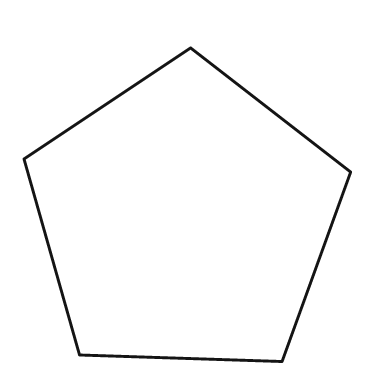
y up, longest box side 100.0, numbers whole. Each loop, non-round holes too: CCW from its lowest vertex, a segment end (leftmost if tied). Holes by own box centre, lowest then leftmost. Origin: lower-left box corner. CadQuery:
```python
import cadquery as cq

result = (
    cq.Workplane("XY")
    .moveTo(79.0, 0.0)
    .lineTo(100.0, 58.0)
    .lineTo(51.0, 96.0)
    .lineTo(0.0, 62.0)
    .lineTo(17.0, 2.0)
    .close()
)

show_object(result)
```